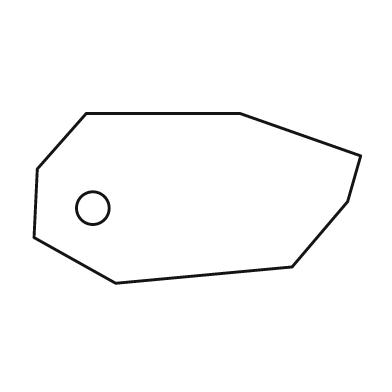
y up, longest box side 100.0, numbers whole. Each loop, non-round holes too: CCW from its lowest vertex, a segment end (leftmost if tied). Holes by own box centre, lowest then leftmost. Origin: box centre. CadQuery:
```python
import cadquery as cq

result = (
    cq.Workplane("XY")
    .moveTo(-25.0, -26.0)
    .lineTo(29.0, -21.0)
    .lineTo(46.0, -1.0)
    .lineTo(50.0, 13.0)
    .lineTo(13.0, 26.0)
    .lineTo(-34.0, 26.0)
    .lineTo(-49.0, 9.0)
    .lineTo(-50.0, -12.0)
    .close()
    .moveTo(-32.0, -3.0)
    .circle(5.0)
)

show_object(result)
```